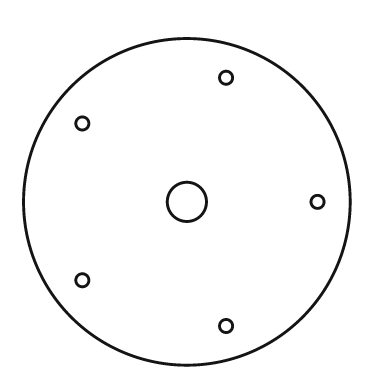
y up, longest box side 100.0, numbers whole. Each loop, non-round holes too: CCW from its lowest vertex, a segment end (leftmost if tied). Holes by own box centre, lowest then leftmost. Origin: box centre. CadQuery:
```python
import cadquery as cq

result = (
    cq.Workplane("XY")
    .moveTo(0.0, 0.0)
    .circle(50.0)
    .moveTo(12.0, -38.0)
    .circle(2.0)
    .moveTo(-32.0, -24.0)
    .circle(2.0)
    .moveTo(0.0, 0.0)
    .circle(6.0)
    .moveTo(40.0, 0.0)
    .circle(2.0)
    .moveTo(-32.0, 24.0)
    .circle(2.0)
    .moveTo(12.0, 38.0)
    .circle(2.0)
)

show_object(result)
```